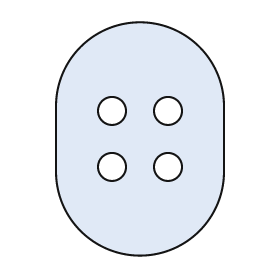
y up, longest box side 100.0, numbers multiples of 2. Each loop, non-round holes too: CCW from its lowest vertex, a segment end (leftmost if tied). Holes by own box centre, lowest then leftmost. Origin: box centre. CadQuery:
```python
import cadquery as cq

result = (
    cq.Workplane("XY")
    .moveTo(-36.0, -14.0)
    .threePointArc((0.0, -50.0), (36.0, -14.0))
    .lineTo(36.0, 14.0)
    .threePointArc((0.0, 50.0), (-36.0, 14.0))
    .close()
    .moveTo(-12.0, -12.0)
    .circle(6.0)
    .moveTo(12.0, -12.0)
    .circle(6.0)
    .moveTo(-12.0, 12.0)
    .circle(6.0)
    .moveTo(12.0, 12.0)
    .circle(6.0)
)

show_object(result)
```